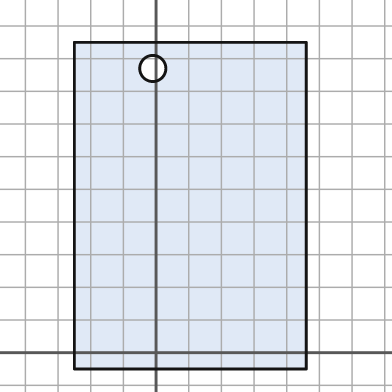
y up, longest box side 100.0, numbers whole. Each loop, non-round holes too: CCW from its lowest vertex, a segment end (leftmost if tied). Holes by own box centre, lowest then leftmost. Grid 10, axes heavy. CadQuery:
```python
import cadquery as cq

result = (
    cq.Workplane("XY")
    .moveTo(-25.0, -5.0)
    .lineTo(46.0, -5.0)
    .lineTo(46.0, 95.0)
    .lineTo(-25.0, 95.0)
    .close()
    .moveTo(-1.0, 87.0)
    .circle(4.0)
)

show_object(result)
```